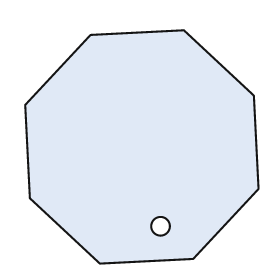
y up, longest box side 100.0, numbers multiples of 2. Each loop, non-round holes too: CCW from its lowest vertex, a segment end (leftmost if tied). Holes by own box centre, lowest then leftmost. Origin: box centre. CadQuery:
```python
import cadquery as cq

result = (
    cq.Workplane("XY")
    .moveTo(-18.0, -50.0)
    .lineTo(22.0, -48.0)
    .lineTo(50.0, -18.0)
    .lineTo(48.0, 22.0)
    .lineTo(18.0, 50.0)
    .lineTo(-22.0, 48.0)
    .lineTo(-50.0, 18.0)
    .lineTo(-48.0, -22.0)
    .close()
    .moveTo(8.0, -34.0)
    .circle(4.0)
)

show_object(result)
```